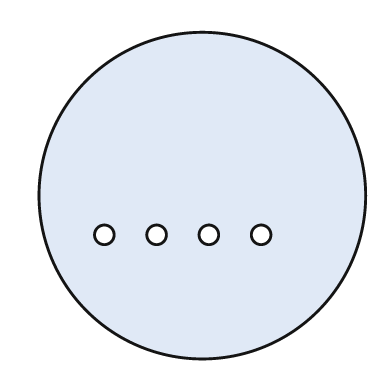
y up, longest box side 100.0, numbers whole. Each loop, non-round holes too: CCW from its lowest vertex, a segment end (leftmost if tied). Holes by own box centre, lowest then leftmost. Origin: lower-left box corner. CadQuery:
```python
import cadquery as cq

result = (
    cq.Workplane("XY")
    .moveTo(50.0, 50.0)
    .circle(50.0)
    .moveTo(20.0, 38.0)
    .circle(3.0)
    .moveTo(36.0, 38.0)
    .circle(3.0)
    .moveTo(52.0, 38.0)
    .circle(3.0)
    .moveTo(68.0, 38.0)
    .circle(3.0)
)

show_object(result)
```